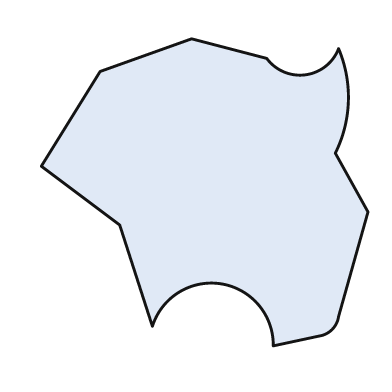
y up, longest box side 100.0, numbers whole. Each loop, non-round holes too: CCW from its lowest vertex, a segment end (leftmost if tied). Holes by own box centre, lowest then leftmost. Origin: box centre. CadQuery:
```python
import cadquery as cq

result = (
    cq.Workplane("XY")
    .moveTo(21.0, -47.0)
    .lineTo(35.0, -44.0)
    .threePointArc((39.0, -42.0), (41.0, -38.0))
    .lineTo(50.0, -6.0)
    .lineTo(40.0, 12.0)
    .threePointArc((44.0, 28.0), (41.0, 44.0))
    .threePointArc((31.0, 36.0), (19.0, 41.0))
    .lineTo(-4.0, 47.0)
    .lineTo(-32.0, 37.0)
    .lineTo(-50.0, 8.0)
    .lineTo(-26.0, -10.0)
    .lineTo(-16.0, -41.0)
    .threePointArc((5.0, -28.0), (21.0, -47.0))
    .close()
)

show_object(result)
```